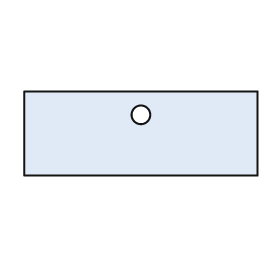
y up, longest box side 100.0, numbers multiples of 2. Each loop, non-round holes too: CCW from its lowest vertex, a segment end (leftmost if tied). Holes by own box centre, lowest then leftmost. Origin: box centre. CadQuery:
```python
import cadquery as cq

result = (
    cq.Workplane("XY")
    .moveTo(-50.0, -18.0)
    .lineTo(50.0, -18.0)
    .lineTo(50.0, 18.0)
    .lineTo(-50.0, 18.0)
    .close()
    .moveTo(0.0, 8.0)
    .circle(4.0)
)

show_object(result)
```